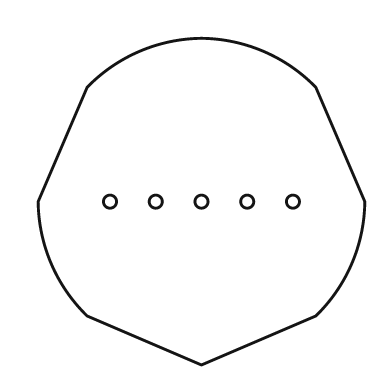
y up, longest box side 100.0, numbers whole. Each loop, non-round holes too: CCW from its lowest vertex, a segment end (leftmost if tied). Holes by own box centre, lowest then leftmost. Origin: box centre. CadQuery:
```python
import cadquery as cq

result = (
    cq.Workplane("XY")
    .moveTo(0.0, -50.0)
    .lineTo(35.0, -35.0)
    .threePointArc((46.0, -19.0), (50.0, 0.0))
    .lineTo(35.0, 35.0)
    .threePointArc((19.0, 46.0), (0.0, 50.0))
    .threePointArc((-19.0, 46.0), (-35.0, 35.0))
    .lineTo(-50.0, 0.0)
    .threePointArc((-46.0, -19.0), (-35.0, -35.0))
    .close()
    .moveTo(-28.0, 0.0)
    .circle(2.0)
    .moveTo(-14.0, 0.0)
    .circle(2.0)
    .moveTo(0.0, 0.0)
    .circle(2.0)
    .moveTo(14.0, 0.0)
    .circle(2.0)
    .moveTo(28.0, 0.0)
    .circle(2.0)
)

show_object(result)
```